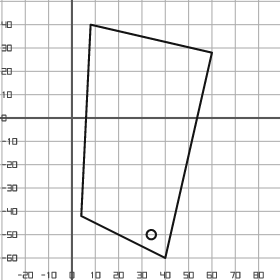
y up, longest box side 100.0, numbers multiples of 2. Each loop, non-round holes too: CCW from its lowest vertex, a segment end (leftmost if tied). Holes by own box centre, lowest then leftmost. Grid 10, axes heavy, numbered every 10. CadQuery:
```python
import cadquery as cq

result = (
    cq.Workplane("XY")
    .moveTo(40.0, -60.0)
    .lineTo(60.0, 28.0)
    .lineTo(8.0, 40.0)
    .lineTo(4.0, -42.0)
    .close()
    .moveTo(34.0, -50.0)
    .circle(2.0)
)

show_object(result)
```